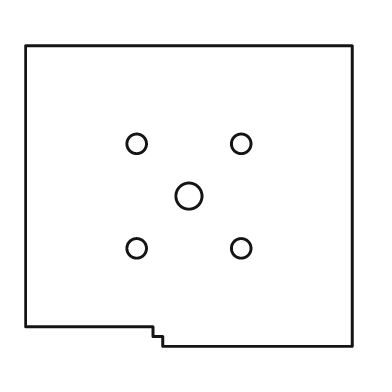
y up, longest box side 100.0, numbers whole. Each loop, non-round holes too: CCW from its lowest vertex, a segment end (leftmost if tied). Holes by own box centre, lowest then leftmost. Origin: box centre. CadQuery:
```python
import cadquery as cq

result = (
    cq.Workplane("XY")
    .moveTo(-8.0, -46.0)
    .lineTo(50.0, -46.0)
    .lineTo(50.0, 46.0)
    .lineTo(-50.0, 46.0)
    .lineTo(-50.0, -40.0)
    .lineTo(-11.0, -40.0)
    .lineTo(-11.0, -43.0)
    .lineTo(-8.0, -43.0)
    .close()
    .moveTo(-16.0, -16.0)
    .circle(3.0)
    .moveTo(16.0, -16.0)
    .circle(3.0)
    .moveTo(0.0, 0.0)
    .circle(4.0)
    .moveTo(-16.0, 16.0)
    .circle(3.0)
    .moveTo(16.0, 16.0)
    .circle(3.0)
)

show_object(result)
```